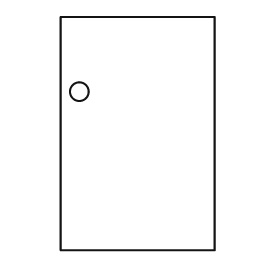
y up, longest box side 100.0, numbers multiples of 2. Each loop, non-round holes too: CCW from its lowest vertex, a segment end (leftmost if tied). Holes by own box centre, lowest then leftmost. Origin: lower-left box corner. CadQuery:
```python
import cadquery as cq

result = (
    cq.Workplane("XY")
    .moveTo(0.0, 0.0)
    .lineTo(66.0, 0.0)
    .lineTo(66.0, 100.0)
    .lineTo(0.0, 100.0)
    .close()
    .moveTo(8.0, 68.0)
    .circle(4.0)
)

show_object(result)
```